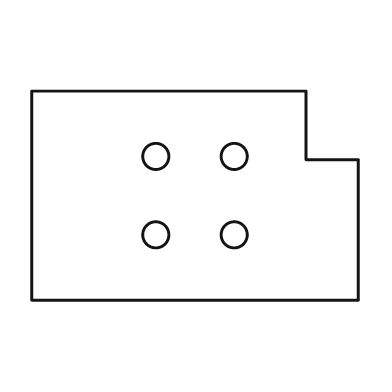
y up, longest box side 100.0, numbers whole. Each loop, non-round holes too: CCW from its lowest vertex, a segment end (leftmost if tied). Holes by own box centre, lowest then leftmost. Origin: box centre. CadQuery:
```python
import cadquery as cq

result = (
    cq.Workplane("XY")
    .moveTo(-50.0, -32.0)
    .lineTo(50.0, -32.0)
    .lineTo(50.0, 11.0)
    .lineTo(34.0, 11.0)
    .lineTo(34.0, 32.0)
    .lineTo(-50.0, 32.0)
    .close()
    .moveTo(-12.0, -12.0)
    .circle(4.0)
    .moveTo(12.0, -12.0)
    .circle(4.0)
    .moveTo(-12.0, 12.0)
    .circle(4.0)
    .moveTo(12.0, 12.0)
    .circle(4.0)
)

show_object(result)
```